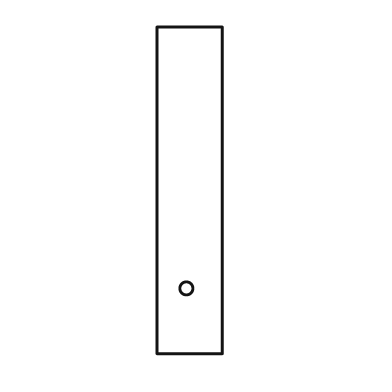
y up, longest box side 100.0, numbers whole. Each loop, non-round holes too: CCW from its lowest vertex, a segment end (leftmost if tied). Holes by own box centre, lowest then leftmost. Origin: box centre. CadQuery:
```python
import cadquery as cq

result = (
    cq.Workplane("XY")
    .moveTo(-10.0, -50.0)
    .lineTo(10.0, -50.0)
    .lineTo(10.0, 50.0)
    .lineTo(-10.0, 50.0)
    .close()
    .moveTo(-1.0, -30.0)
    .circle(2.0)
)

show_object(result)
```